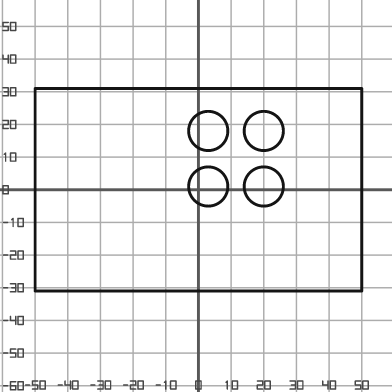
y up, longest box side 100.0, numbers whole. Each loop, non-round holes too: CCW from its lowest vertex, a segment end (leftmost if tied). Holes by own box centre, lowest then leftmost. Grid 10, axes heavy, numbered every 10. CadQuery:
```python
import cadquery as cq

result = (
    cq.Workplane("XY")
    .moveTo(-50.0, -31.0)
    .lineTo(50.0, -31.0)
    .lineTo(50.0, 31.0)
    .lineTo(-50.0, 31.0)
    .close()
    .moveTo(3.0, 1.0)
    .circle(6.0)
    .moveTo(20.0, 1.0)
    .circle(6.0)
    .moveTo(3.0, 18.0)
    .circle(6.0)
    .moveTo(20.0, 18.0)
    .circle(6.0)
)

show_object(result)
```